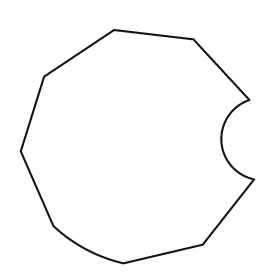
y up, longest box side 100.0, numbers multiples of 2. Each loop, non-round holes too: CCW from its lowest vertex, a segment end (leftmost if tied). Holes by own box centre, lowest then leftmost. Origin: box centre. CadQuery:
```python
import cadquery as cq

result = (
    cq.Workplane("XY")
    .moveTo(-6.0, -50.0)
    .lineTo(28.0, -42.0)
    .lineTo(50.0, -14.0)
    .threePointArc((36.0, 2.0), (48.0, 20.0))
    .lineTo(24.0, 46.0)
    .lineTo(-10.0, 50.0)
    .lineTo(-40.0, 30.0)
    .lineTo(-50.0, -2.0)
    .lineTo(-36.0, -34.0)
    .threePointArc((-22.0, -44.0), (-6.0, -50.0))
    .close()
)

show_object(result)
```